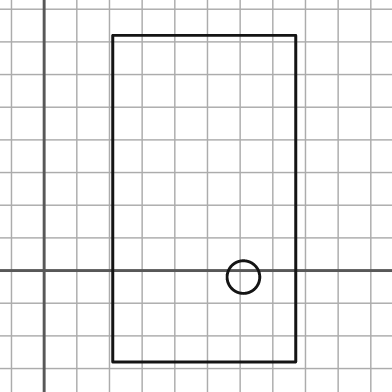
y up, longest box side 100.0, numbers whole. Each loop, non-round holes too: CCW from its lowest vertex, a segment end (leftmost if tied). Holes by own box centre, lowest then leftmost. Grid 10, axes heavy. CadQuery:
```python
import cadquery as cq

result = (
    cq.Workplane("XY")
    .moveTo(21.0, -28.0)
    .lineTo(77.0, -28.0)
    .lineTo(77.0, 72.0)
    .lineTo(21.0, 72.0)
    .close()
    .moveTo(61.0, -2.0)
    .circle(5.0)
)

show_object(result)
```